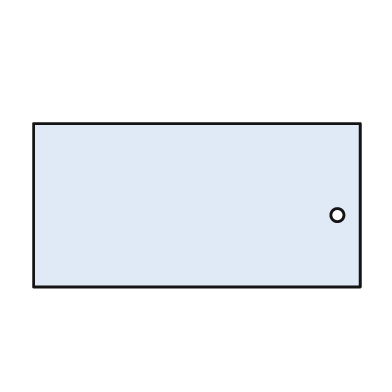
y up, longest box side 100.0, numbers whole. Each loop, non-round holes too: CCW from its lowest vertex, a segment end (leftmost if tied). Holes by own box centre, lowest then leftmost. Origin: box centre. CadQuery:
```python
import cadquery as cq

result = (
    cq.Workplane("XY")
    .moveTo(-50.0, -25.0)
    .lineTo(50.0, -25.0)
    .lineTo(50.0, 25.0)
    .lineTo(-50.0, 25.0)
    .close()
    .moveTo(43.0, -3.0)
    .circle(2.0)
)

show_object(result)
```